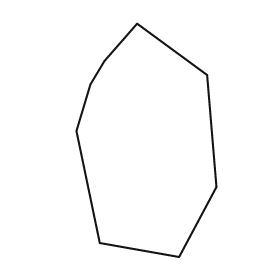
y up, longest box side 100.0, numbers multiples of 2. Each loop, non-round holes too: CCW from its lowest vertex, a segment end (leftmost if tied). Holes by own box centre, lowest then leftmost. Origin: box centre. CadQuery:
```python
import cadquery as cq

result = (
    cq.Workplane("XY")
    .moveTo(14.0, -50.0)
    .lineTo(30.0, -20.0)
    .lineTo(26.0, 28.0)
    .lineTo(-4.0, 50.0)
    .lineTo(-18.0, 34.0)
    .lineTo(-24.0, 24.0)
    .lineTo(-30.0, 4.0)
    .lineTo(-20.0, -44.0)
    .close()
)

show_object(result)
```